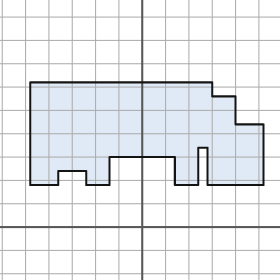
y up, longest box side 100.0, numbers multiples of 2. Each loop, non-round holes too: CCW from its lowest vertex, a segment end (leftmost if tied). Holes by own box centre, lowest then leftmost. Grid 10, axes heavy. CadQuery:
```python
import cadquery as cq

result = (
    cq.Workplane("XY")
    .moveTo(-48.0, 18.0)
    .lineTo(-36.0, 18.0)
    .lineTo(-36.0, 24.0)
    .lineTo(-24.0, 24.0)
    .lineTo(-24.0, 18.0)
    .lineTo(-14.0, 18.0)
    .lineTo(-14.0, 30.0)
    .lineTo(14.0, 30.0)
    .lineTo(14.0, 18.0)
    .lineTo(24.0, 18.0)
    .lineTo(24.0, 34.0)
    .lineTo(28.0, 34.0)
    .lineTo(28.0, 18.0)
    .lineTo(52.0, 18.0)
    .lineTo(52.0, 44.0)
    .lineTo(40.0, 44.0)
    .lineTo(40.0, 56.0)
    .lineTo(30.0, 56.0)
    .lineTo(30.0, 62.0)
    .lineTo(-48.0, 62.0)
    .close()
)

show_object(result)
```